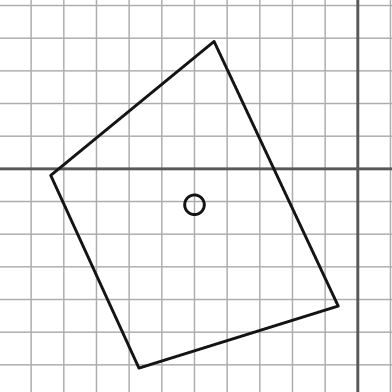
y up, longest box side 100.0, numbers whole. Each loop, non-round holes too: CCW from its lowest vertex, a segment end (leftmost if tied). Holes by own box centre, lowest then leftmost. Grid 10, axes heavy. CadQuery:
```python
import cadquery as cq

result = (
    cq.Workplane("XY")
    .moveTo(-67.0, -61.0)
    .lineTo(-6.0, -42.0)
    .lineTo(-44.0, 39.0)
    .lineTo(-94.0, -2.0)
    .close()
    .moveTo(-50.0, -11.0)
    .circle(3.0)
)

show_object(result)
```